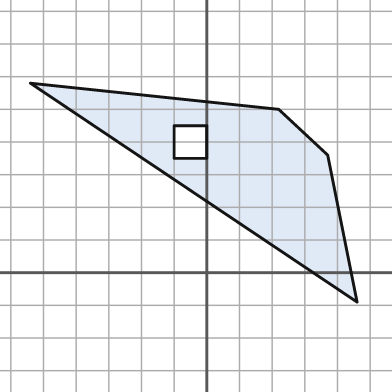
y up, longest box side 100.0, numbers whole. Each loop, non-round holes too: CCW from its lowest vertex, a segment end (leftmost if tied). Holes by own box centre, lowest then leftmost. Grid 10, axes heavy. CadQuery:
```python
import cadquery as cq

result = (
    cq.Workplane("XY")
    .moveTo(46.0, -9.0)
    .lineTo(37.0, 36.0)
    .lineTo(22.0, 50.0)
    .lineTo(-54.0, 58.0)
    .close()
    .moveTo(-10.0, 35.0)
    .lineTo(0.0, 35.0)
    .lineTo(0.0, 45.0)
    .lineTo(-10.0, 45.0)
    .close()
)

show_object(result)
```